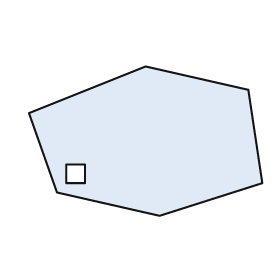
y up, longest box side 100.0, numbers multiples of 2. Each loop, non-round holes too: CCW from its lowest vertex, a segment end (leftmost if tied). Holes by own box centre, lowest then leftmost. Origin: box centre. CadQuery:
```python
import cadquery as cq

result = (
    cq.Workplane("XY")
    .moveTo(6.0, -32.0)
    .lineTo(50.0, -18.0)
    .lineTo(44.0, 22.0)
    .lineTo(0.0, 32.0)
    .lineTo(-50.0, 12.0)
    .lineTo(-38.0, -22.0)
    .close()
    .moveTo(-34.0, -18.0)
    .lineTo(-26.0, -18.0)
    .lineTo(-26.0, -10.0)
    .lineTo(-34.0, -10.0)
    .close()
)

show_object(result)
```